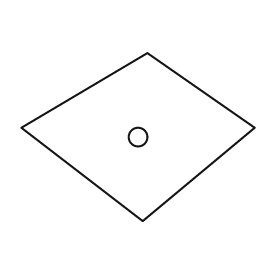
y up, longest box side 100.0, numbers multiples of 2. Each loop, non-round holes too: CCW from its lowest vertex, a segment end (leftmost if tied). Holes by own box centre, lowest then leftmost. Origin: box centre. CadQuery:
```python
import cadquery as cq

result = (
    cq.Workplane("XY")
    .moveTo(2.0, -36.0)
    .lineTo(50.0, 4.0)
    .lineTo(4.0, 36.0)
    .lineTo(-50.0, 4.0)
    .close()
    .moveTo(0.0, 0.0)
    .circle(4.0)
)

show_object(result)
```